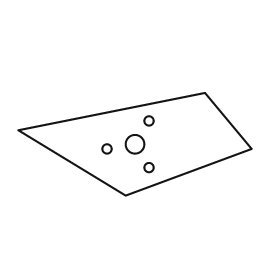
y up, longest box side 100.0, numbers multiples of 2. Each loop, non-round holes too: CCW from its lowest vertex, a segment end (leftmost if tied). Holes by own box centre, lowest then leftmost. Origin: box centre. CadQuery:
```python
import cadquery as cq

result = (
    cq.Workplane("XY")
    .moveTo(-4.0, -22.0)
    .lineTo(50.0, -2.0)
    .lineTo(30.0, 22.0)
    .lineTo(-50.0, 6.0)
    .close()
    .moveTo(6.0, -10.0)
    .circle(2.0)
    .moveTo(-12.0, -2.0)
    .circle(2.0)
    .moveTo(0.0, 0.0)
    .circle(4.0)
    .moveTo(6.0, 10.0)
    .circle(2.0)
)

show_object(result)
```